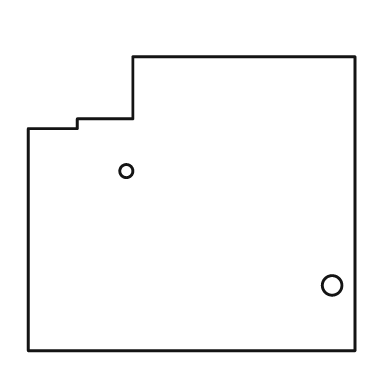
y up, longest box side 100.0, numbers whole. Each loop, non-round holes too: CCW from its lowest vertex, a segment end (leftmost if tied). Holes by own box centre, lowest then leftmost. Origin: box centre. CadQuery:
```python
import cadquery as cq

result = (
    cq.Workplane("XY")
    .moveTo(-50.0, -45.0)
    .lineTo(50.0, -45.0)
    .lineTo(50.0, 45.0)
    .lineTo(-18.0, 45.0)
    .lineTo(-18.0, 26.0)
    .lineTo(-35.0, 26.0)
    .lineTo(-35.0, 23.0)
    .lineTo(-50.0, 23.0)
    .close()
    .moveTo(43.0, -25.0)
    .circle(3.0)
    .moveTo(-20.0, 10.0)
    .circle(2.0)
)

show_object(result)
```